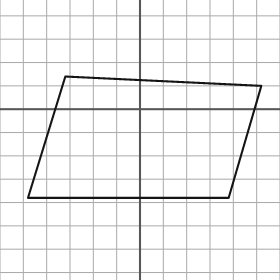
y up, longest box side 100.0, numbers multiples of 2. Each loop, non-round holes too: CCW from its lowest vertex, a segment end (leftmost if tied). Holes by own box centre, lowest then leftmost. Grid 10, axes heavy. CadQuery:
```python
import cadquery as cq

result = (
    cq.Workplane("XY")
    .moveTo(-48.0, -38.0)
    .lineTo(38.0, -38.0)
    .lineTo(52.0, 10.0)
    .lineTo(-32.0, 14.0)
    .close()
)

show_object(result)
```